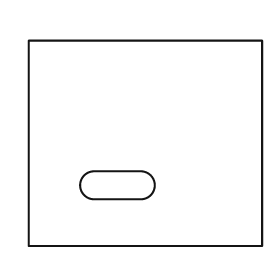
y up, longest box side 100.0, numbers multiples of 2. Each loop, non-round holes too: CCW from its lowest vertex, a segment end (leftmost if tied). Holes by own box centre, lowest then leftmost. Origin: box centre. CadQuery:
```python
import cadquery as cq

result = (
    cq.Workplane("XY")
    .moveTo(-50.0, -44.0)
    .lineTo(50.0, -44.0)
    .lineTo(50.0, 44.0)
    .lineTo(-50.0, 44.0)
    .close()
    .moveTo(-22.0, -24.0)
    .lineTo(-2.0, -24.0)
    .threePointArc((4.0, -18.0), (-2.0, -12.0))
    .lineTo(-22.0, -12.0)
    .threePointArc((-28.0, -18.0), (-22.0, -24.0))
    .close()
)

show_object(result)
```